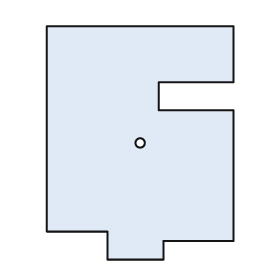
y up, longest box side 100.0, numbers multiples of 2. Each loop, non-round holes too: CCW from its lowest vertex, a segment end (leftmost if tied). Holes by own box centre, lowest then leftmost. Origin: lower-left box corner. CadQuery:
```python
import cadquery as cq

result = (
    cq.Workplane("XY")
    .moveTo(26.0, 0.0)
    .lineTo(50.0, 0.0)
    .lineTo(50.0, 8.0)
    .lineTo(80.0, 8.0)
    .lineTo(80.0, 64.0)
    .lineTo(48.0, 64.0)
    .lineTo(48.0, 76.0)
    .lineTo(80.0, 76.0)
    .lineTo(80.0, 100.0)
    .lineTo(0.0, 100.0)
    .lineTo(0.0, 12.0)
    .lineTo(26.0, 12.0)
    .close()
    .moveTo(40.0, 50.0)
    .circle(2.0)
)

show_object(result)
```